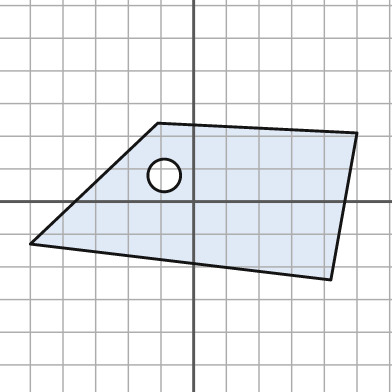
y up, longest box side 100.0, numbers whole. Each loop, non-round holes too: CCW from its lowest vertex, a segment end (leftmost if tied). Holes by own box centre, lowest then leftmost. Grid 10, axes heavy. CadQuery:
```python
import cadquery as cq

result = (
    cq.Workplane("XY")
    .moveTo(42.0, -24.0)
    .lineTo(50.0, 21.0)
    .lineTo(-11.0, 24.0)
    .lineTo(-50.0, -13.0)
    .close()
    .moveTo(-9.0, 8.0)
    .circle(5.0)
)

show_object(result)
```